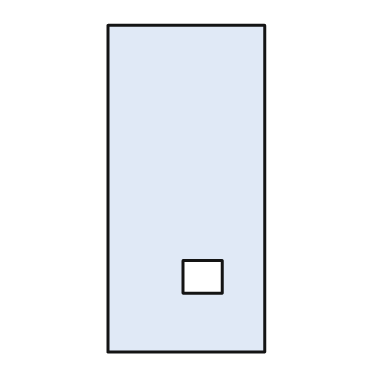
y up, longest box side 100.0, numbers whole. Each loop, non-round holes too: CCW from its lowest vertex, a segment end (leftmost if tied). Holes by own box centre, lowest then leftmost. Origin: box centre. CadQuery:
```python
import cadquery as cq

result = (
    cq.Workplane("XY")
    .moveTo(-24.0, -50.0)
    .lineTo(24.0, -50.0)
    .lineTo(24.0, 50.0)
    .lineTo(-24.0, 50.0)
    .close()
    .moveTo(-1.0, -32.0)
    .lineTo(11.0, -32.0)
    .lineTo(11.0, -22.0)
    .lineTo(-1.0, -22.0)
    .close()
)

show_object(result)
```